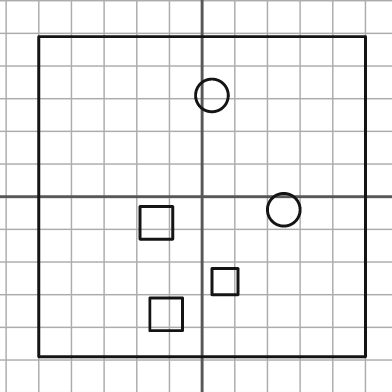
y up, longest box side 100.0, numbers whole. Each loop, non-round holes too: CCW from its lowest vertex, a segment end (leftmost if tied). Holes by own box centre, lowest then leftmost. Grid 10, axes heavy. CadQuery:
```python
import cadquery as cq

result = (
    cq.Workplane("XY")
    .moveTo(-50.0, -49.0)
    .lineTo(50.0, -49.0)
    .lineTo(50.0, 49.0)
    .lineTo(-50.0, 49.0)
    .close()
    .moveTo(-16.0, -41.0)
    .lineTo(-6.0, -41.0)
    .lineTo(-6.0, -31.0)
    .lineTo(-16.0, -31.0)
    .close()
    .moveTo(3.0, -30.0)
    .lineTo(11.0, -30.0)
    .lineTo(11.0, -22.0)
    .lineTo(3.0, -22.0)
    .close()
    .moveTo(-19.0, -13.0)
    .lineTo(-9.0, -13.0)
    .lineTo(-9.0, -3.0)
    .lineTo(-19.0, -3.0)
    .close()
    .moveTo(25.0, -4.0)
    .circle(5.0)
    .moveTo(3.0, 31.0)
    .circle(5.0)
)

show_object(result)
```